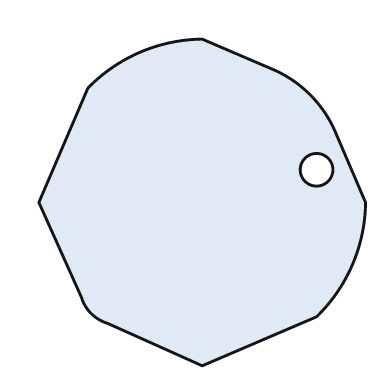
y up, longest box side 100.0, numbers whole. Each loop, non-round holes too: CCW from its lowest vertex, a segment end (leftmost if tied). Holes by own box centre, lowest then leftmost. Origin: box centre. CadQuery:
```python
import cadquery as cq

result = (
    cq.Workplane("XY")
    .moveTo(0.0, -50.0)
    .lineTo(35.0, -35.0)
    .threePointArc((46.0, -19.0), (50.0, 0.0))
    .lineTo(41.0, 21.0)
    .threePointArc((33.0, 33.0), (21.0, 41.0))
    .lineTo(0.0, 50.0)
    .threePointArc((-19.0, 46.0), (-35.0, 35.0))
    .lineTo(-50.0, 0.0)
    .lineTo(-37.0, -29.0)
    .threePointArc((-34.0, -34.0), (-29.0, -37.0))
    .close()
    .moveTo(35.0, 10.0)
    .circle(5.0)
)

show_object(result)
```